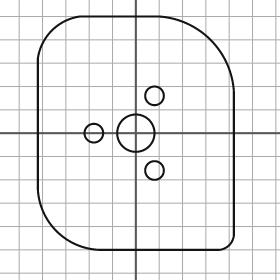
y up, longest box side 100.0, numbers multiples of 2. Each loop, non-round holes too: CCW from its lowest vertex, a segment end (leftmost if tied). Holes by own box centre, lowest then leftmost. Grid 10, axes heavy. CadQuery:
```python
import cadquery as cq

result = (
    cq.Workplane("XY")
    .moveTo(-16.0, -50.0)
    .lineTo(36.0, -50.0)
    .threePointArc((40.0, -48.0), (42.0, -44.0))
    .lineTo(42.0, 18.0)
    .threePointArc((32.0, 40.0), (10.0, 50.0))
    .lineTo(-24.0, 50.0)
    .threePointArc((-36.0, 44.0), (-42.0, 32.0))
    .lineTo(-42.0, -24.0)
    .threePointArc((-34.0, -42.0), (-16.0, -50.0))
    .close()
    .moveTo(8.0, -16.0)
    .circle(4.0)
    .moveTo(-18.0, 0.0)
    .circle(4.0)
    .moveTo(0.0, 0.0)
    .circle(8.0)
    .moveTo(8.0, 16.0)
    .circle(4.0)
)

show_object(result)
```